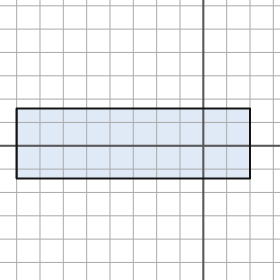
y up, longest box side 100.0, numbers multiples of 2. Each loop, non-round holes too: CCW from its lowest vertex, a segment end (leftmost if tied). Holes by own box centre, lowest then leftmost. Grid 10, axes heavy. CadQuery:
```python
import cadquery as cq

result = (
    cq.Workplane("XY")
    .moveTo(-80.0, -14.0)
    .lineTo(20.0, -14.0)
    .lineTo(20.0, 16.0)
    .lineTo(-80.0, 16.0)
    .close()
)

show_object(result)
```